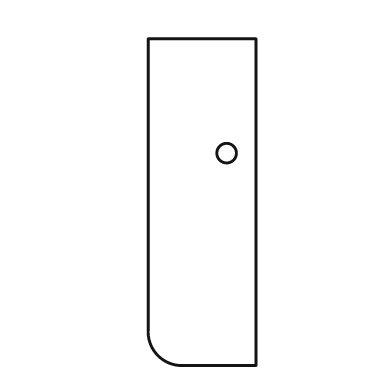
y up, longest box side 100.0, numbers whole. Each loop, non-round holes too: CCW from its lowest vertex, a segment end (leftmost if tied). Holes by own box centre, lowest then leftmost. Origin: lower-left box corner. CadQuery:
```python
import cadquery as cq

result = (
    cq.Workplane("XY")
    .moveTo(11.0, 0.0)
    .lineTo(33.0, 0.0)
    .lineTo(33.0, 100.0)
    .lineTo(0.0, 100.0)
    .lineTo(0.0, 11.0)
    .threePointArc((3.0, 3.0), (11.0, 0.0))
    .close()
    .moveTo(24.0, 65.0)
    .circle(3.0)
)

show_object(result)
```